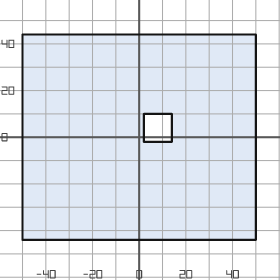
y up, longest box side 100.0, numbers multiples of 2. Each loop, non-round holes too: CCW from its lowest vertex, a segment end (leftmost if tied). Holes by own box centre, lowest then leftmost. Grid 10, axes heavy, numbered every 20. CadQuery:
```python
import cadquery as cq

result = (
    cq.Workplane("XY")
    .moveTo(-50.0, -44.0)
    .lineTo(50.0, -44.0)
    .lineTo(50.0, 44.0)
    .lineTo(-50.0, 44.0)
    .close()
    .moveTo(2.0, -2.0)
    .lineTo(14.0, -2.0)
    .lineTo(14.0, 10.0)
    .lineTo(2.0, 10.0)
    .close()
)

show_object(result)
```